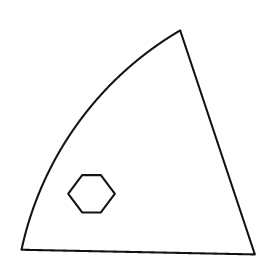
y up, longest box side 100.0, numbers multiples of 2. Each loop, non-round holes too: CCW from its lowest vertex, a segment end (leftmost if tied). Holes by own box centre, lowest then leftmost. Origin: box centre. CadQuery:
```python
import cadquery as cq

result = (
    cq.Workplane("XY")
    .moveTo(50.0, -48.0)
    .lineTo(18.0, 48.0)
    .threePointArc((-26.0, 8.0), (-50.0, -46.0))
    .close()
    .moveTo(-24.0, -30.0)
    .lineTo(-16.0, -30.0)
    .lineTo(-10.0, -22.0)
    .lineTo(-16.0, -14.0)
    .lineTo(-24.0, -14.0)
    .lineTo(-30.0, -22.0)
    .close()
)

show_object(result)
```